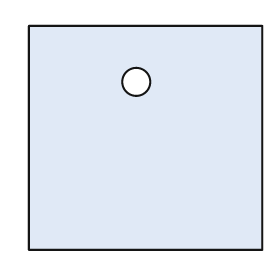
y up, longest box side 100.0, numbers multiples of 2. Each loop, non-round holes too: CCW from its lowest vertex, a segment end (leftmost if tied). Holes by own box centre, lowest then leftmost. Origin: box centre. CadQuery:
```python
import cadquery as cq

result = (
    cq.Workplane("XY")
    .moveTo(-50.0, -48.0)
    .lineTo(50.0, -48.0)
    .lineTo(50.0, 48.0)
    .lineTo(-50.0, 48.0)
    .close()
    .moveTo(-4.0, 24.0)
    .circle(6.0)
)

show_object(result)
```